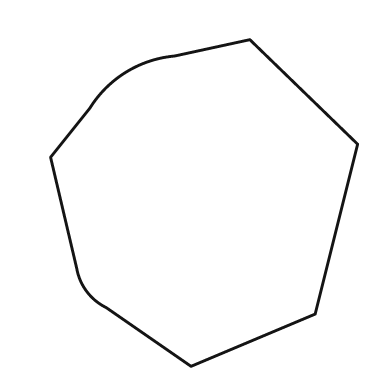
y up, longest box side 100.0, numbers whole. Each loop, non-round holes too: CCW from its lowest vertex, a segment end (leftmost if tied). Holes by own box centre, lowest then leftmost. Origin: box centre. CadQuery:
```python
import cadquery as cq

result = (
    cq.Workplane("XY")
    .moveTo(-4.0, -50.0)
    .lineTo(34.0, -34.0)
    .lineTo(47.0, 18.0)
    .lineTo(14.0, 50.0)
    .lineTo(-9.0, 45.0)
    .threePointArc((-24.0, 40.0), (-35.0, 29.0))
    .lineTo(-47.0, 14.0)
    .lineTo(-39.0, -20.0)
    .threePointArc((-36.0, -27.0), (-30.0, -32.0))
    .close()
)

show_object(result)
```